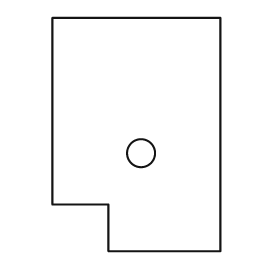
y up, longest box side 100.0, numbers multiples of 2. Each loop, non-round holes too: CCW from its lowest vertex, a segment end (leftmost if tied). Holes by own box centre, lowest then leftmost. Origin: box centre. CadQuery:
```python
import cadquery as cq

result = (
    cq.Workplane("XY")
    .moveTo(-12.0, -50.0)
    .lineTo(36.0, -50.0)
    .lineTo(36.0, 50.0)
    .lineTo(-36.0, 50.0)
    .lineTo(-36.0, -30.0)
    .lineTo(-12.0, -30.0)
    .close()
    .moveTo(2.0, -8.0)
    .circle(6.0)
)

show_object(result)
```